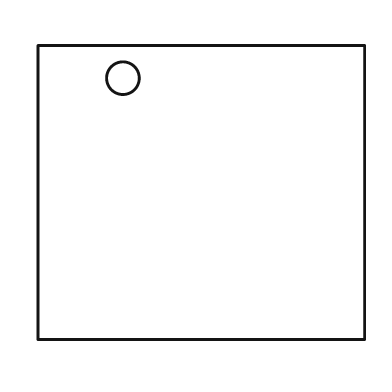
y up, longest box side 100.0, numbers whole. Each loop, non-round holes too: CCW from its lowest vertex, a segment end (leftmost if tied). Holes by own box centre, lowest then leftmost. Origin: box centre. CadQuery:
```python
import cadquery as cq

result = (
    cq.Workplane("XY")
    .moveTo(-50.0, -45.0)
    .lineTo(50.0, -45.0)
    .lineTo(50.0, 45.0)
    .lineTo(-50.0, 45.0)
    .close()
    .moveTo(-24.0, 35.0)
    .circle(5.0)
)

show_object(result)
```